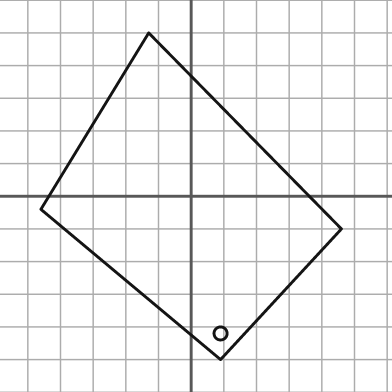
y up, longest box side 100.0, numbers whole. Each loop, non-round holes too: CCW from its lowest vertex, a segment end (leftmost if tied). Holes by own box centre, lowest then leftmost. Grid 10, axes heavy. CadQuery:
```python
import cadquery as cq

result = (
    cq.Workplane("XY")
    .moveTo(9.0, -50.0)
    .lineTo(46.0, -10.0)
    .lineTo(-13.0, 50.0)
    .lineTo(-46.0, -4.0)
    .close()
    .moveTo(9.0, -42.0)
    .circle(2.0)
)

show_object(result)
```